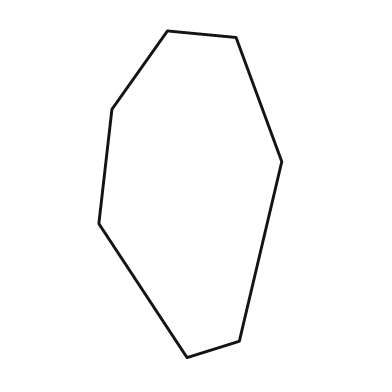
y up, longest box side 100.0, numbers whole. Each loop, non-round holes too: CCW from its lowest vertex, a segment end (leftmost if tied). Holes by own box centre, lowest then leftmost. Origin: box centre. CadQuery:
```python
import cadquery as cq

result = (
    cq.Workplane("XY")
    .moveTo(-1.0, -50.0)
    .lineTo(15.0, -45.0)
    .lineTo(28.0, 10.0)
    .lineTo(14.0, 48.0)
    .lineTo(-7.0, 50.0)
    .lineTo(-24.0, 26.0)
    .lineTo(-28.0, -9.0)
    .close()
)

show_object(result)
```